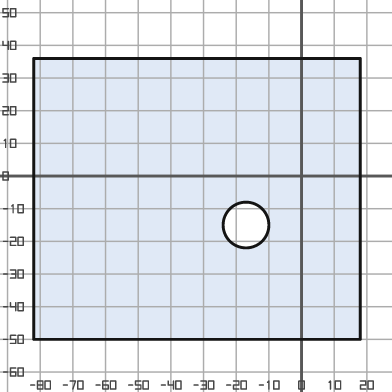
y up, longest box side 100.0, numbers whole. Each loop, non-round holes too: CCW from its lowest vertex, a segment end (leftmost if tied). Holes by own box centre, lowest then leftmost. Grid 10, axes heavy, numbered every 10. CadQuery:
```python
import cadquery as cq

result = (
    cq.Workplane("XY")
    .moveTo(-82.0, -50.0)
    .lineTo(18.0, -50.0)
    .lineTo(18.0, 36.0)
    .lineTo(-82.0, 36.0)
    .close()
    .moveTo(-17.0, -15.0)
    .circle(7.0)
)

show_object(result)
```